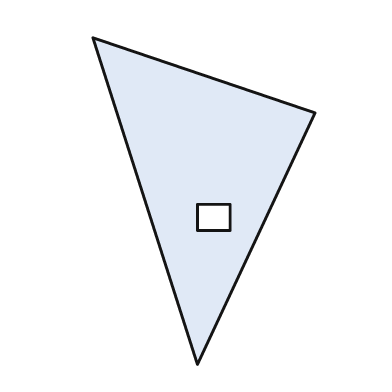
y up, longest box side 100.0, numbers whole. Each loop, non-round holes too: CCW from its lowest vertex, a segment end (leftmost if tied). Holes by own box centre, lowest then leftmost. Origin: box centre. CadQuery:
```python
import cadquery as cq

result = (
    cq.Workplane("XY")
    .moveTo(-2.0, -50.0)
    .lineTo(34.0, 27.0)
    .lineTo(-34.0, 50.0)
    .close()
    .moveTo(-2.0, -9.0)
    .lineTo(8.0, -9.0)
    .lineTo(8.0, -1.0)
    .lineTo(-2.0, -1.0)
    .close()
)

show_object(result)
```